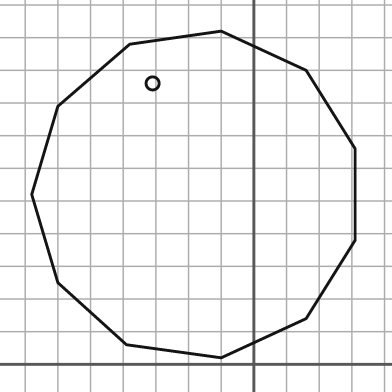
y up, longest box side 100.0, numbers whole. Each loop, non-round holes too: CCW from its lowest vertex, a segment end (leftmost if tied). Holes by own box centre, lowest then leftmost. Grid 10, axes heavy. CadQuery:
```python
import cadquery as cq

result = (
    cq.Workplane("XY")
    .moveTo(-10.0, 2.0)
    .lineTo(16.0, 14.0)
    .lineTo(31.0, 38.0)
    .lineTo(31.0, 66.0)
    .lineTo(16.0, 90.0)
    .lineTo(-10.0, 102.0)
    .lineTo(-38.0, 98.0)
    .lineTo(-60.0, 79.0)
    .lineTo(-68.0, 52.0)
    .lineTo(-60.0, 25.0)
    .lineTo(-39.0, 6.0)
    .close()
    .moveTo(-31.0, 86.0)
    .circle(2.0)
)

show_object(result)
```